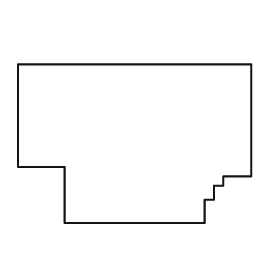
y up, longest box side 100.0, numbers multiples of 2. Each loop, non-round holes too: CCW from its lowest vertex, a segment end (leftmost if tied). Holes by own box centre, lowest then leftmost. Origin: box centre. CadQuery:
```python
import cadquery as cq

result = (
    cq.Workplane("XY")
    .moveTo(-30.0, -34.0)
    .lineTo(30.0, -34.0)
    .lineTo(30.0, -24.0)
    .lineTo(34.0, -24.0)
    .lineTo(34.0, -18.0)
    .lineTo(38.0, -18.0)
    .lineTo(38.0, -14.0)
    .lineTo(50.0, -14.0)
    .lineTo(50.0, 34.0)
    .lineTo(-50.0, 34.0)
    .lineTo(-50.0, -10.0)
    .lineTo(-30.0, -10.0)
    .close()
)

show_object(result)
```